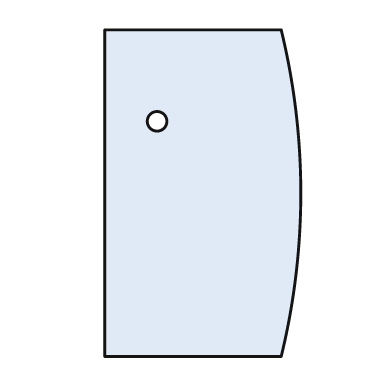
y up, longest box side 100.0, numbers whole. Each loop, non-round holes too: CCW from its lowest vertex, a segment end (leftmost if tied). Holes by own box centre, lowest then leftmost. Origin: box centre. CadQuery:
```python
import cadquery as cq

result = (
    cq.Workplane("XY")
    .moveTo(-30.0, -50.0)
    .lineTo(24.0, -50.0)
    .threePointArc((30.0, 0.0), (24.0, 50.0))
    .lineTo(-30.0, 50.0)
    .close()
    .moveTo(-14.0, 22.0)
    .circle(3.0)
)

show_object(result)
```